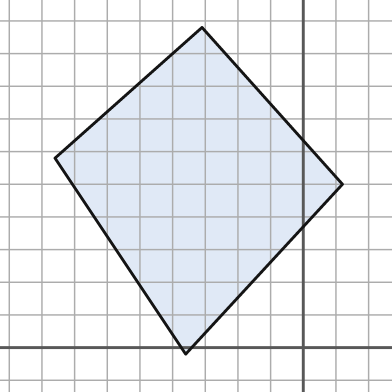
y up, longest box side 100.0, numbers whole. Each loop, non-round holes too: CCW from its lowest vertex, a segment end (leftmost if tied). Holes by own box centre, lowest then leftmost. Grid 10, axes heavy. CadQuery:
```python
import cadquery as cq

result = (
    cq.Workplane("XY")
    .moveTo(-36.0, -2.0)
    .lineTo(12.0, 50.0)
    .lineTo(-31.0, 98.0)
    .lineTo(-76.0, 58.0)
    .close()
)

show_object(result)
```